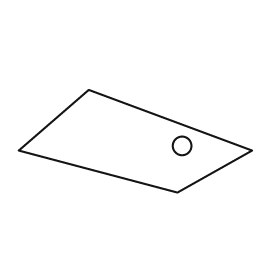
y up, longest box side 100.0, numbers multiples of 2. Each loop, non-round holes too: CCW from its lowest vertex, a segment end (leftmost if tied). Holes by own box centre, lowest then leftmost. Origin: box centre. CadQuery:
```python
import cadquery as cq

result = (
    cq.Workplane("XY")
    .moveTo(18.0, -22.0)
    .lineTo(50.0, -4.0)
    .lineTo(-20.0, 22.0)
    .lineTo(-50.0, -4.0)
    .close()
    .moveTo(20.0, -2.0)
    .circle(4.0)
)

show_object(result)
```